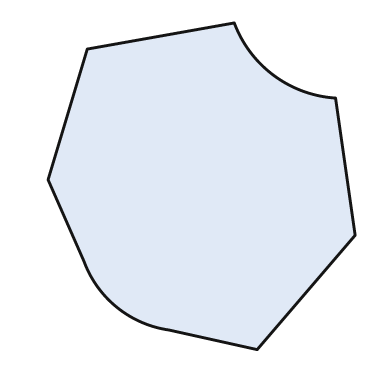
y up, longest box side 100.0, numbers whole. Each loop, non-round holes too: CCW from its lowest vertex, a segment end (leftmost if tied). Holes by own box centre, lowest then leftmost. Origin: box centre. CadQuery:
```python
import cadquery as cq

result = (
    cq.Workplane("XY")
    .moveTo(17.0, -50.0)
    .lineTo(47.0, -15.0)
    .lineTo(41.0, 27.0)
    .threePointArc((22.0, 34.0), (10.0, 50.0))
    .lineTo(-35.0, 42.0)
    .lineTo(-47.0, 2.0)
    .lineTo(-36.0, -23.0)
    .threePointArc((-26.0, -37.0), (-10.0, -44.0))
    .close()
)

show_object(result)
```